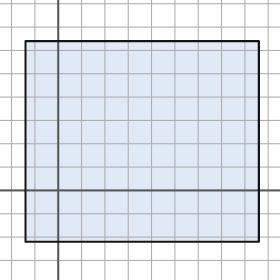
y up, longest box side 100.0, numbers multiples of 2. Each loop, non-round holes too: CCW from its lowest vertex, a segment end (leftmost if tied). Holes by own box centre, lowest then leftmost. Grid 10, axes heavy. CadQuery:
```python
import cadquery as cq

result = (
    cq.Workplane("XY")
    .moveTo(-14.0, -22.0)
    .lineTo(86.0, -22.0)
    .lineTo(86.0, 64.0)
    .lineTo(-14.0, 64.0)
    .close()
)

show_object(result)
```